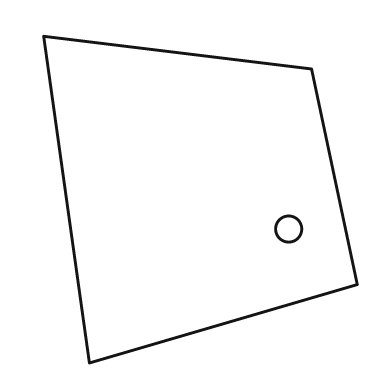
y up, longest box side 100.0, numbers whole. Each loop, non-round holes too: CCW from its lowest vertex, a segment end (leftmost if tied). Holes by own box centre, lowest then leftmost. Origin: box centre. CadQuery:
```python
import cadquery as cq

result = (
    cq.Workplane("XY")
    .moveTo(-34.0, -50.0)
    .lineTo(48.0, -26.0)
    .lineTo(34.0, 40.0)
    .lineTo(-48.0, 50.0)
    .close()
    .moveTo(27.0, -9.0)
    .circle(4.0)
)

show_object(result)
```